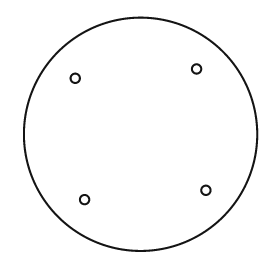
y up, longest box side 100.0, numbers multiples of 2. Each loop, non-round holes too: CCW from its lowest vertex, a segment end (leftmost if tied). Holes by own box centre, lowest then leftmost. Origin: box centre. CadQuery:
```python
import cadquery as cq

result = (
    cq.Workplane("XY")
    .moveTo(0.0, 0.0)
    .circle(50.0)
    .moveTo(-24.0, -28.0)
    .circle(2.0)
    .moveTo(28.0, -24.0)
    .circle(2.0)
    .moveTo(-28.0, 24.0)
    .circle(2.0)
    .moveTo(24.0, 28.0)
    .circle(2.0)
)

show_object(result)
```